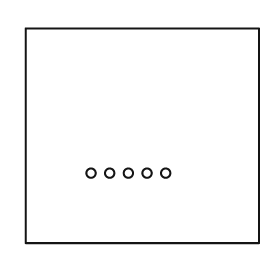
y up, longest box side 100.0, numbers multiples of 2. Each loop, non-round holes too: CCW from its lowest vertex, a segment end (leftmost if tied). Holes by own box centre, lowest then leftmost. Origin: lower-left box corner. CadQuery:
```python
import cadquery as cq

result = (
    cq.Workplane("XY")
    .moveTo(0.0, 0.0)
    .lineTo(100.0, 0.0)
    .lineTo(100.0, 92.0)
    .lineTo(0.0, 92.0)
    .close()
    .moveTo(28.0, 30.0)
    .circle(2.0)
    .moveTo(36.0, 30.0)
    .circle(2.0)
    .moveTo(44.0, 30.0)
    .circle(2.0)
    .moveTo(52.0, 30.0)
    .circle(2.0)
    .moveTo(60.0, 30.0)
    .circle(2.0)
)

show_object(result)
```